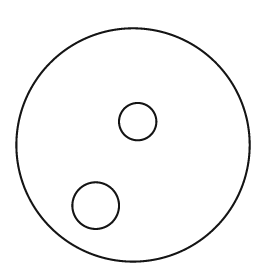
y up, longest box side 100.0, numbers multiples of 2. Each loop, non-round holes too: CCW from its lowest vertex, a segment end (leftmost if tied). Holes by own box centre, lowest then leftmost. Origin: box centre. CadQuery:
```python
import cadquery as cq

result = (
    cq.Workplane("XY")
    .moveTo(0.0, 0.0)
    .circle(50.0)
    .moveTo(-16.0, -26.0)
    .circle(10.0)
    .moveTo(2.0, 10.0)
    .circle(8.0)
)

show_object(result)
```